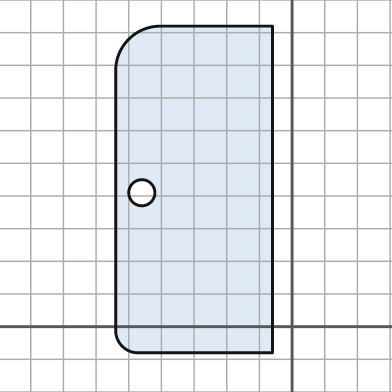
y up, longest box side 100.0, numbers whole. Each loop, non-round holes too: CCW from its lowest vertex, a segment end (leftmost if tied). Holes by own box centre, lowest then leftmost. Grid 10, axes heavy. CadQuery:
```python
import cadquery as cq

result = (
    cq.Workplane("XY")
    .moveTo(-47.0, -8.0)
    .lineTo(-6.0, -8.0)
    .lineTo(-6.0, 92.0)
    .lineTo(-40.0, 92.0)
    .threePointArc((-50.0, 88.0), (-54.0, 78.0))
    .lineTo(-54.0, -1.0)
    .threePointArc((-52.0, -6.0), (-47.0, -8.0))
    .close()
    .moveTo(-46.0, 41.0)
    .circle(4.0)
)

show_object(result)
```